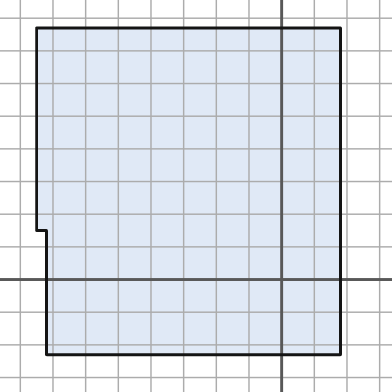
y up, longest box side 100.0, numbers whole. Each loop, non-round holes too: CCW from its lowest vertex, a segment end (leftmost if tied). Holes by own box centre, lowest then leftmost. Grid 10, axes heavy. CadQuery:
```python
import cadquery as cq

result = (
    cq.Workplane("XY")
    .moveTo(-72.0, -23.0)
    .lineTo(18.0, -23.0)
    .lineTo(18.0, 77.0)
    .lineTo(-75.0, 77.0)
    .lineTo(-75.0, 15.0)
    .lineTo(-72.0, 15.0)
    .close()
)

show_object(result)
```